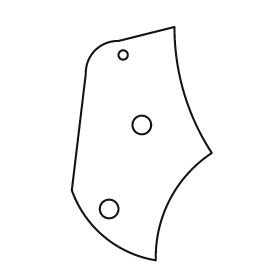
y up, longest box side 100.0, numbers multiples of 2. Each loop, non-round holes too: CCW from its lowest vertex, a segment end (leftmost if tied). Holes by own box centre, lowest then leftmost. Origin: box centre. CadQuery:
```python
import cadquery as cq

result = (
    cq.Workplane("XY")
    .moveTo(6.0, -50.0)
    .threePointArc((12.0, -24.0), (30.0, -4.0))
    .threePointArc((18.0, 22.0), (14.0, 50.0))
    .lineTo(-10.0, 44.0)
    .threePointArc((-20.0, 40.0), (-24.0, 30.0))
    .lineTo(-30.0, -20.0)
    .threePointArc((-16.0, -40.0), (6.0, -50.0))
    .close()
    .moveTo(-14.0, -28.0)
    .circle(4.0)
    .moveTo(0.0, 8.0)
    .circle(4.0)
    .moveTo(-8.0, 38.0)
    .circle(2.0)
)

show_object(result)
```